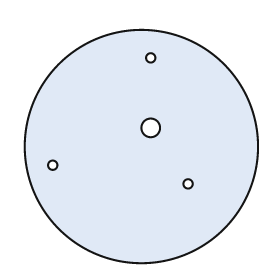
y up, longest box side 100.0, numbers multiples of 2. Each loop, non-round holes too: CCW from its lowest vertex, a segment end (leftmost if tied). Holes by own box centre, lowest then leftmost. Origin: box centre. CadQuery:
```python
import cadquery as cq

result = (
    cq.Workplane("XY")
    .moveTo(0.0, 0.0)
    .circle(50.0)
    .moveTo(20.0, -16.0)
    .circle(2.0)
    .moveTo(-38.0, -8.0)
    .circle(2.0)
    .moveTo(4.0, 8.0)
    .circle(4.0)
    .moveTo(4.0, 38.0)
    .circle(2.0)
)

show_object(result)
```